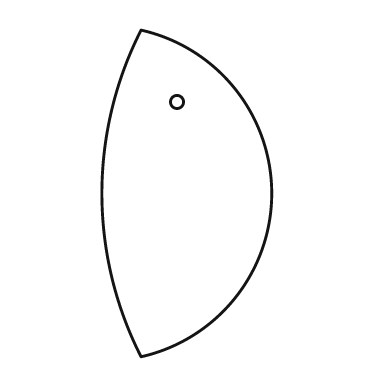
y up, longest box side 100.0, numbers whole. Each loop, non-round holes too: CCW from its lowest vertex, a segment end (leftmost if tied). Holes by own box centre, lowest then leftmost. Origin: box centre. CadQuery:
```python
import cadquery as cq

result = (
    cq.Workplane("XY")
    .moveTo(-14.0, -50.0)
    .threePointArc((26.0, 0.0), (-14.0, 50.0))
    .threePointArc((-26.0, 0.0), (-14.0, -50.0))
    .close()
    .moveTo(-3.0, 28.0)
    .circle(2.0)
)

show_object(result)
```